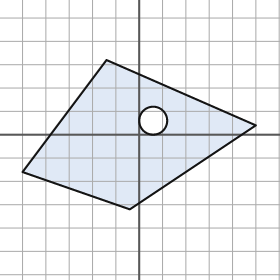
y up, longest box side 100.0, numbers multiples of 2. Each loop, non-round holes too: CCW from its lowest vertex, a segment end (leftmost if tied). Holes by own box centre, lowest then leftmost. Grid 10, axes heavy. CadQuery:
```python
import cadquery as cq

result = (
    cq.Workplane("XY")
    .moveTo(-4.0, -32.0)
    .lineTo(50.0, 4.0)
    .lineTo(-14.0, 32.0)
    .lineTo(-50.0, -16.0)
    .close()
    .moveTo(6.0, 6.0)
    .circle(6.0)
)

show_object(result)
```